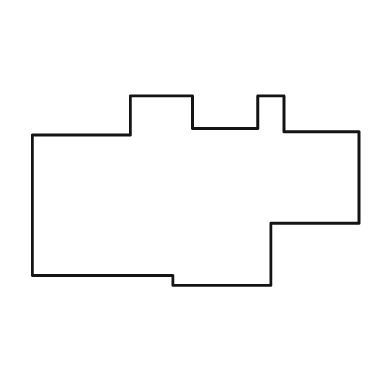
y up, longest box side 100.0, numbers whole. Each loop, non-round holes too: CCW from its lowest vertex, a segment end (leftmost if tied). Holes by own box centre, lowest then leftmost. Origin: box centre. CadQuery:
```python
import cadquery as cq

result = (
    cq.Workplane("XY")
    .moveTo(-7.0, -29.0)
    .lineTo(23.0, -29.0)
    .lineTo(23.0, -10.0)
    .lineTo(50.0, -10.0)
    .lineTo(50.0, 18.0)
    .lineTo(27.0, 18.0)
    .lineTo(27.0, 29.0)
    .lineTo(19.0, 29.0)
    .lineTo(19.0, 19.0)
    .lineTo(-1.0, 19.0)
    .lineTo(-1.0, 29.0)
    .lineTo(-20.0, 29.0)
    .lineTo(-20.0, 17.0)
    .lineTo(-50.0, 17.0)
    .lineTo(-50.0, -26.0)
    .lineTo(-7.0, -26.0)
    .close()
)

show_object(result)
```